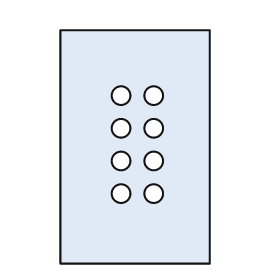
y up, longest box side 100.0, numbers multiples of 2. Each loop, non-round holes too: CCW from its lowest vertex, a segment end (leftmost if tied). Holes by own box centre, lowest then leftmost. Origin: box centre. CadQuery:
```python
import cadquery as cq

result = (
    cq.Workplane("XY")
    .moveTo(-32.0, -50.0)
    .lineTo(32.0, -50.0)
    .lineTo(32.0, 50.0)
    .lineTo(-32.0, 50.0)
    .close()
    .moveTo(-6.0, -20.0)
    .circle(4.0)
    .moveTo(8.0, -20.0)
    .circle(4.0)
    .moveTo(-6.0, -6.0)
    .circle(4.0)
    .moveTo(8.0, -6.0)
    .circle(4.0)
    .moveTo(-6.0, 8.0)
    .circle(4.0)
    .moveTo(8.0, 8.0)
    .circle(4.0)
    .moveTo(-6.0, 22.0)
    .circle(4.0)
    .moveTo(8.0, 22.0)
    .circle(4.0)
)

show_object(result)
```